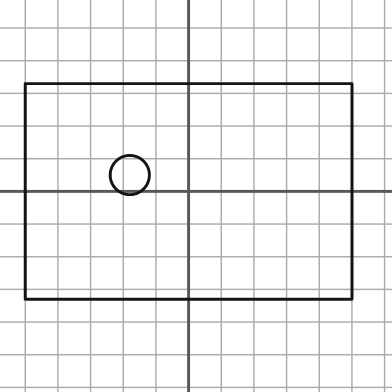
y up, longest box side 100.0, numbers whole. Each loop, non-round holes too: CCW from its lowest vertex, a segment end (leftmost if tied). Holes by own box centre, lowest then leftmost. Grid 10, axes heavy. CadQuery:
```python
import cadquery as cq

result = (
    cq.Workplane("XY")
    .moveTo(-50.0, -33.0)
    .lineTo(50.0, -33.0)
    .lineTo(50.0, 33.0)
    .lineTo(-50.0, 33.0)
    .close()
    .moveTo(-18.0, 5.0)
    .circle(6.0)
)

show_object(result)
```